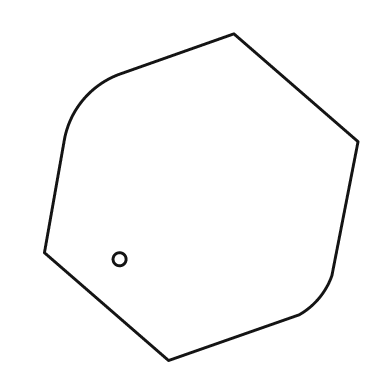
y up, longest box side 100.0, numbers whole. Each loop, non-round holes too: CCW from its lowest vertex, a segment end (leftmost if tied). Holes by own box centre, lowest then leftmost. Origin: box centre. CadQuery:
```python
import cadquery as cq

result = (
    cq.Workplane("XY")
    .moveTo(-10.0, -50.0)
    .lineTo(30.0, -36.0)
    .threePointArc((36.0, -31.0), (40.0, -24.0))
    .lineTo(48.0, 17.0)
    .lineTo(10.0, 50.0)
    .lineTo(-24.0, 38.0)
    .threePointArc((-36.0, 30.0), (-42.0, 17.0))
    .lineTo(-48.0, -17.0)
    .close()
    .moveTo(-25.0, -19.0)
    .circle(2.0)
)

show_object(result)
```